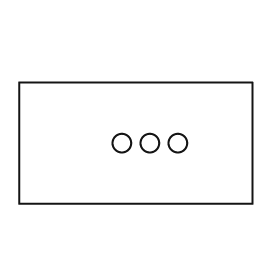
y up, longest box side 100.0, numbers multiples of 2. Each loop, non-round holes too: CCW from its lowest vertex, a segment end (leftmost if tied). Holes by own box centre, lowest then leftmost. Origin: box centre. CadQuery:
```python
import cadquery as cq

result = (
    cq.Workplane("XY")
    .moveTo(-50.0, -26.0)
    .lineTo(50.0, -26.0)
    .lineTo(50.0, 26.0)
    .lineTo(-50.0, 26.0)
    .close()
    .moveTo(-6.0, 0.0)
    .circle(4.0)
    .moveTo(6.0, 0.0)
    .circle(4.0)
    .moveTo(18.0, 0.0)
    .circle(4.0)
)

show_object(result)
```